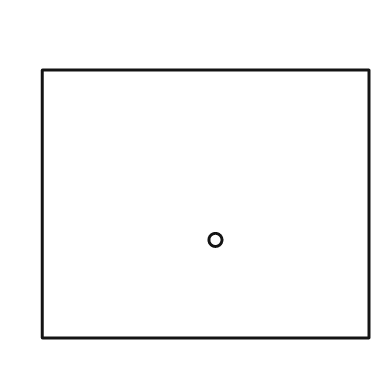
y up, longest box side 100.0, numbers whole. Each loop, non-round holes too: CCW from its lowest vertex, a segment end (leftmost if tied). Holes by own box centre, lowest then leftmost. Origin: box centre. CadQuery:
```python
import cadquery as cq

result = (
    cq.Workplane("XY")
    .moveTo(-50.0, -41.0)
    .lineTo(50.0, -41.0)
    .lineTo(50.0, 41.0)
    .lineTo(-50.0, 41.0)
    .close()
    .moveTo(3.0, -11.0)
    .circle(2.0)
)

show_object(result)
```